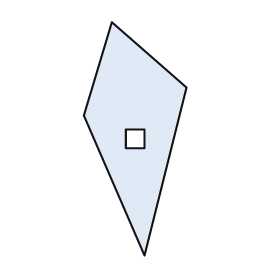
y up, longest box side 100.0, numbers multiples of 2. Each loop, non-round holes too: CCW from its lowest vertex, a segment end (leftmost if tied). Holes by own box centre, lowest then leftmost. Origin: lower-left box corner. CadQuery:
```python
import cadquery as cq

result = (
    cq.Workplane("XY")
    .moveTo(26.0, 0.0)
    .lineTo(44.0, 72.0)
    .lineTo(12.0, 100.0)
    .lineTo(0.0, 60.0)
    .close()
    .moveTo(18.0, 46.0)
    .lineTo(26.0, 46.0)
    .lineTo(26.0, 54.0)
    .lineTo(18.0, 54.0)
    .close()
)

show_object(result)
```